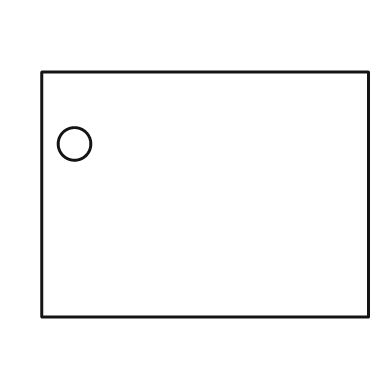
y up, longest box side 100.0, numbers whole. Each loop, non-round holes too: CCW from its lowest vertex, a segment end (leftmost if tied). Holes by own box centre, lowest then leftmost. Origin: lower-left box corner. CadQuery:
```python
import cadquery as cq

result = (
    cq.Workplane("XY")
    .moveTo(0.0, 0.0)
    .lineTo(100.0, 0.0)
    .lineTo(100.0, 75.0)
    .lineTo(0.0, 75.0)
    .close()
    .moveTo(10.0, 53.0)
    .circle(5.0)
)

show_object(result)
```